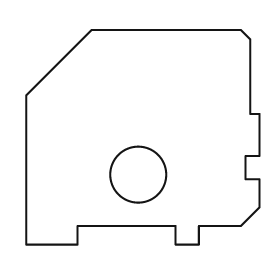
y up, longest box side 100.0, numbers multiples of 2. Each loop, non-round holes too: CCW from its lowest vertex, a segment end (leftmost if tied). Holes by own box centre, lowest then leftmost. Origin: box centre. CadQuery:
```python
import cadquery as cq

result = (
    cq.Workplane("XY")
    .moveTo(-50.0, -46.0)
    .lineTo(-28.0, -46.0)
    .lineTo(-28.0, -38.0)
    .lineTo(14.0, -38.0)
    .lineTo(14.0, -46.0)
    .lineTo(24.0, -46.0)
    .lineTo(24.0, -38.0)
    .lineTo(42.0, -38.0)
    .lineTo(50.0, -30.0)
    .lineTo(50.0, -18.0)
    .lineTo(44.0, -18.0)
    .lineTo(44.0, -8.0)
    .lineTo(50.0, -8.0)
    .lineTo(50.0, 10.0)
    .lineTo(46.0, 10.0)
    .lineTo(46.0, 42.0)
    .lineTo(42.0, 46.0)
    .lineTo(-22.0, 46.0)
    .lineTo(-50.0, 18.0)
    .close()
    .moveTo(-2.0, -16.0)
    .circle(12.0)
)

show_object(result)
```